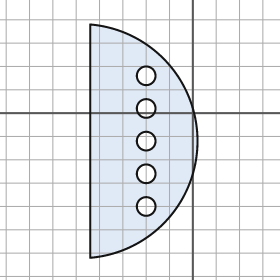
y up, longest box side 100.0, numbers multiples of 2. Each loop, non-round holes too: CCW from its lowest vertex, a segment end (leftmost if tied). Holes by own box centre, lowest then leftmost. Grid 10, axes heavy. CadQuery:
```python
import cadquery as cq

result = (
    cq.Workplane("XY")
    .moveTo(-44.0, -62.0)
    .threePointArc((2.0, -12.0), (-44.0, 38.0))
    .close()
    .moveTo(-20.0, -40.0)
    .circle(4.0)
    .moveTo(-20.0, -26.0)
    .circle(4.0)
    .moveTo(-20.0, -12.0)
    .circle(4.0)
    .moveTo(-20.0, 2.0)
    .circle(4.0)
    .moveTo(-20.0, 16.0)
    .circle(4.0)
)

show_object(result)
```